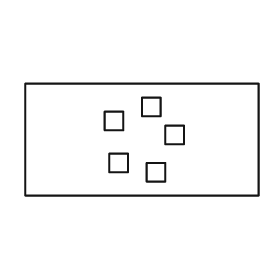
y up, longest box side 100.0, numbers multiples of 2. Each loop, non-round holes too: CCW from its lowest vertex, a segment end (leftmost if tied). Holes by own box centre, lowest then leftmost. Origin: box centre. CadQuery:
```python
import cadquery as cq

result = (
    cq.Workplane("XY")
    .moveTo(-50.0, -24.0)
    .lineTo(50.0, -24.0)
    .lineTo(50.0, 24.0)
    .lineTo(-50.0, 24.0)
    .close()
    .moveTo(2.0, -18.0)
    .lineTo(10.0, -18.0)
    .lineTo(10.0, -10.0)
    .lineTo(2.0, -10.0)
    .close()
    .moveTo(-14.0, -14.0)
    .lineTo(-6.0, -14.0)
    .lineTo(-6.0, -6.0)
    .lineTo(-14.0, -6.0)
    .close()
    .moveTo(10.0, -2.0)
    .lineTo(18.0, -2.0)
    .lineTo(18.0, 6.0)
    .lineTo(10.0, 6.0)
    .close()
    .moveTo(-16.0, 4.0)
    .lineTo(-8.0, 4.0)
    .lineTo(-8.0, 12.0)
    .lineTo(-16.0, 12.0)
    .close()
    .moveTo(0.0, 10.0)
    .lineTo(8.0, 10.0)
    .lineTo(8.0, 18.0)
    .lineTo(0.0, 18.0)
    .close()
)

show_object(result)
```